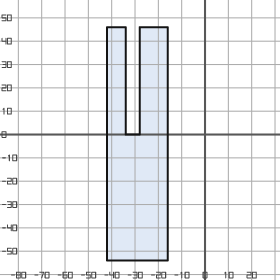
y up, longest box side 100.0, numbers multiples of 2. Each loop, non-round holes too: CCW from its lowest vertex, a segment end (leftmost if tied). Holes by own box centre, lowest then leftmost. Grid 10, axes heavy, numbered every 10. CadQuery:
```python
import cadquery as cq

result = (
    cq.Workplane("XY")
    .moveTo(-42.0, -54.0)
    .lineTo(-16.0, -54.0)
    .lineTo(-16.0, 46.0)
    .lineTo(-28.0, 46.0)
    .lineTo(-28.0, 0.0)
    .lineTo(-34.0, 0.0)
    .lineTo(-34.0, 46.0)
    .lineTo(-42.0, 46.0)
    .close()
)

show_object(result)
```